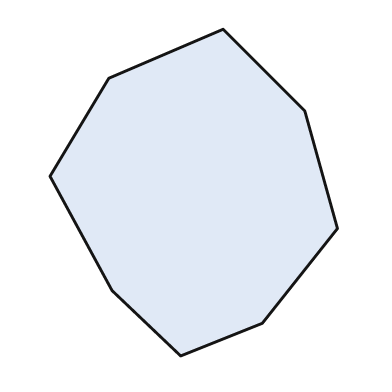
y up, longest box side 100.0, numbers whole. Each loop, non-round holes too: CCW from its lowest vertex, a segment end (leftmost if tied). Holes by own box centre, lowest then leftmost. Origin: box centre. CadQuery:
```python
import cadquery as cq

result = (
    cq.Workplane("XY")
    .moveTo(-4.0, -50.0)
    .lineTo(21.0, -40.0)
    .lineTo(44.0, -11.0)
    .lineTo(34.0, 25.0)
    .lineTo(9.0, 50.0)
    .lineTo(-26.0, 35.0)
    .lineTo(-44.0, 5.0)
    .lineTo(-25.0, -30.0)
    .close()
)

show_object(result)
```